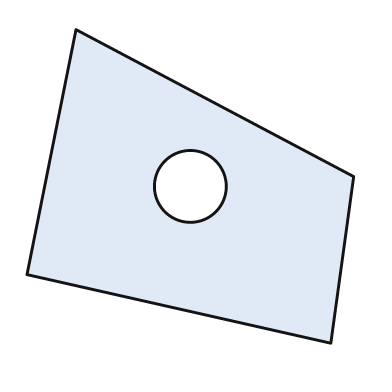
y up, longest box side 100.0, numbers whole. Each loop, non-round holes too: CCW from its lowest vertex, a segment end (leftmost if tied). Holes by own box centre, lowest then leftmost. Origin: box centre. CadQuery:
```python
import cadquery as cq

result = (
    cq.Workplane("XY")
    .moveTo(43.0, -48.0)
    .lineTo(50.0, 3.0)
    .lineTo(-35.0, 48.0)
    .lineTo(-50.0, -27.0)
    .close()
    .moveTo(0.0, 0.0)
    .circle(11.0)
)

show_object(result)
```